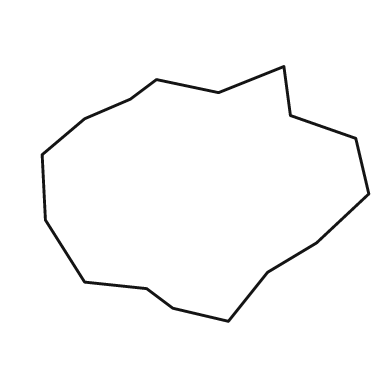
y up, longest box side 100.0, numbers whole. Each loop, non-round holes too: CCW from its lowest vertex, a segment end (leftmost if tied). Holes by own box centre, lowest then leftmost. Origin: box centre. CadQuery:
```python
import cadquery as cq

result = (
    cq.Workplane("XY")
    .moveTo(7.0, -39.0)
    .lineTo(19.0, -24.0)
    .lineTo(34.0, -15.0)
    .lineTo(50.0, 0.0)
    .lineTo(46.0, 17.0)
    .lineTo(26.0, 24.0)
    .lineTo(24.0, 39.0)
    .lineTo(4.0, 31.0)
    .lineTo(-15.0, 35.0)
    .lineTo(-23.0, 29.0)
    .lineTo(-37.0, 23.0)
    .lineTo(-50.0, 12.0)
    .lineTo(-49.0, -8.0)
    .lineTo(-37.0, -27.0)
    .lineTo(-18.0, -29.0)
    .lineTo(-10.0, -35.0)
    .close()
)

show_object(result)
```